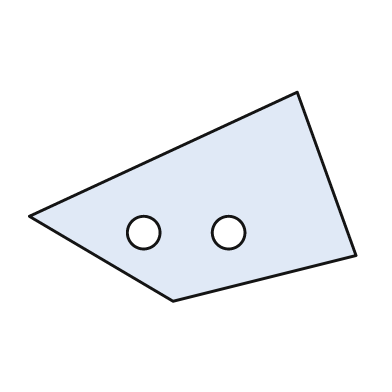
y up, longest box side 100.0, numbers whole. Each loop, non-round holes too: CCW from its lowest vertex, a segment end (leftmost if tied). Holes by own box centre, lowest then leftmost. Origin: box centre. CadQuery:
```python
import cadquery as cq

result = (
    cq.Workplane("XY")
    .moveTo(-6.0, -32.0)
    .lineTo(50.0, -18.0)
    .lineTo(32.0, 32.0)
    .lineTo(-50.0, -6.0)
    .close()
    .moveTo(-15.0, -11.0)
    .circle(5.0)
    .moveTo(11.0, -11.0)
    .circle(5.0)
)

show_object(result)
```